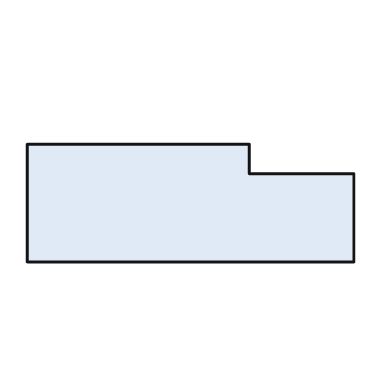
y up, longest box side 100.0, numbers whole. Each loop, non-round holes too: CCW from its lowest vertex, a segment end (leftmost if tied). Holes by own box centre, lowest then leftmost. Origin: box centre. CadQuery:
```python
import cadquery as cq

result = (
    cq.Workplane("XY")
    .moveTo(-50.0, -18.0)
    .lineTo(50.0, -18.0)
    .lineTo(50.0, 9.0)
    .lineTo(18.0, 9.0)
    .lineTo(18.0, 18.0)
    .lineTo(-50.0, 18.0)
    .close()
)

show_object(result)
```